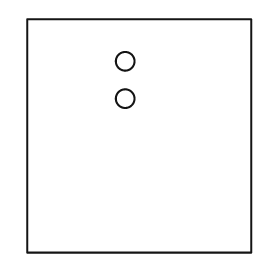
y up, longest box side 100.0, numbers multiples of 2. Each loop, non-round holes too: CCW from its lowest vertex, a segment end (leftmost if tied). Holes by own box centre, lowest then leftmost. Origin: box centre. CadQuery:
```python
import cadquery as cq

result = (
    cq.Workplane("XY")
    .moveTo(-48.0, -50.0)
    .lineTo(48.0, -50.0)
    .lineTo(48.0, 50.0)
    .lineTo(-48.0, 50.0)
    .close()
    .moveTo(-6.0, 16.0)
    .circle(4.0)
    .moveTo(-6.0, 32.0)
    .circle(4.0)
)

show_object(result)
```